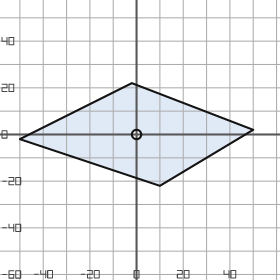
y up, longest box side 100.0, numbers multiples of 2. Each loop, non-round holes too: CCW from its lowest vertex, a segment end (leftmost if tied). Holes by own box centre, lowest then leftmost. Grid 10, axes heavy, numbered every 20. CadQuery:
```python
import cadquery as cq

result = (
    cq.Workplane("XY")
    .moveTo(10.0, -22.0)
    .lineTo(50.0, 2.0)
    .lineTo(-2.0, 22.0)
    .lineTo(-50.0, -2.0)
    .close()
    .moveTo(0.0, 0.0)
    .circle(2.0)
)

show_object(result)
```